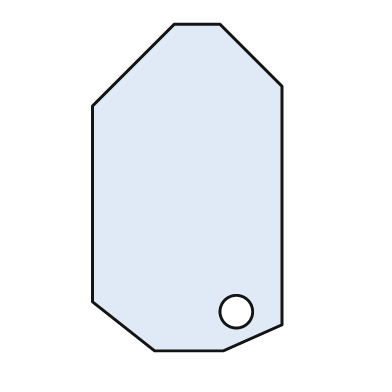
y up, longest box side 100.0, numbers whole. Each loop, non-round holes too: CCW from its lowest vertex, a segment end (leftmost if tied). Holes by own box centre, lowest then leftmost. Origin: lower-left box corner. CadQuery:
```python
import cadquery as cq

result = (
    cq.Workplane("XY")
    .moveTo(19.0, 0.0)
    .lineTo(40.0, 0.0)
    .lineTo(58.0, 8.0)
    .lineTo(58.0, 81.0)
    .lineTo(39.0, 100.0)
    .lineTo(25.0, 100.0)
    .lineTo(0.0, 75.0)
    .lineTo(0.0, 15.0)
    .close()
    .moveTo(44.0, 12.0)
    .circle(5.0)
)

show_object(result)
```